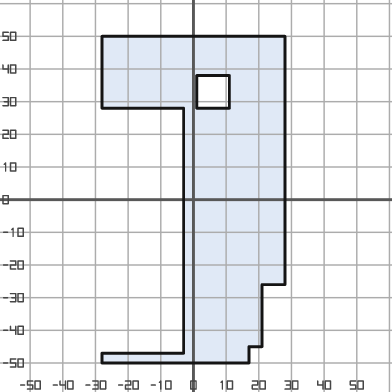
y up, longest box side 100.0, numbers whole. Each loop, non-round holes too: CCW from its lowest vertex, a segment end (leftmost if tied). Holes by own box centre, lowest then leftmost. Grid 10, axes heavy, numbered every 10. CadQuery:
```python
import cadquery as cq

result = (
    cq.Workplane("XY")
    .moveTo(-28.0, -50.0)
    .lineTo(17.0, -50.0)
    .lineTo(17.0, -45.0)
    .lineTo(21.0, -45.0)
    .lineTo(21.0, -26.0)
    .lineTo(28.0, -26.0)
    .lineTo(28.0, 50.0)
    .lineTo(-28.0, 50.0)
    .lineTo(-28.0, 28.0)
    .lineTo(-3.0, 28.0)
    .lineTo(-3.0, -47.0)
    .lineTo(-28.0, -47.0)
    .close()
    .moveTo(1.0, 28.0)
    .lineTo(11.0, 28.0)
    .lineTo(11.0, 38.0)
    .lineTo(1.0, 38.0)
    .close()
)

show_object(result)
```